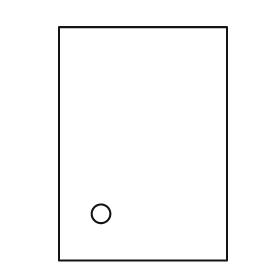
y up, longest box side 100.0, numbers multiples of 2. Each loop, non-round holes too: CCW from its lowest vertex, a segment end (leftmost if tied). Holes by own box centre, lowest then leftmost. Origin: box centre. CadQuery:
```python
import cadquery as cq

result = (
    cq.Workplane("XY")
    .moveTo(-36.0, -50.0)
    .lineTo(36.0, -50.0)
    .lineTo(36.0, 50.0)
    .lineTo(-36.0, 50.0)
    .close()
    .moveTo(-18.0, -30.0)
    .circle(4.0)
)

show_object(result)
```